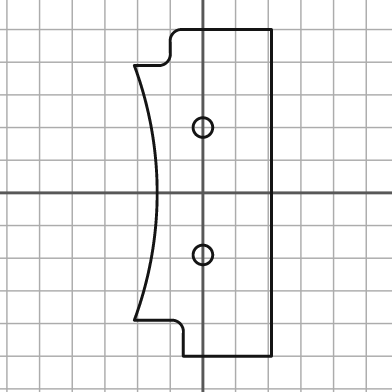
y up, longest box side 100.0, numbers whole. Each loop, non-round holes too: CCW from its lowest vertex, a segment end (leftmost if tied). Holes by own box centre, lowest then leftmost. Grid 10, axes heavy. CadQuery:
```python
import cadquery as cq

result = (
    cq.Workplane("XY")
    .moveTo(-6.0, -50.0)
    .lineTo(21.0, -50.0)
    .lineTo(21.0, 50.0)
    .lineTo(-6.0, 50.0)
    .threePointArc((-9.0, 49.0), (-10.0, 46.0))
    .lineTo(-10.0, 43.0)
    .threePointArc((-11.0, 40.0), (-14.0, 39.0))
    .lineTo(-21.0, 39.0)
    .threePointArc((-14.0, 0.0), (-21.0, -39.0))
    .lineTo(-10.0, -39.0)
    .threePointArc((-7.0, -40.0), (-6.0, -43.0))
    .close()
    .moveTo(0.0, -19.0)
    .circle(3.0)
    .moveTo(0.0, 20.0)
    .circle(3.0)
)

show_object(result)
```